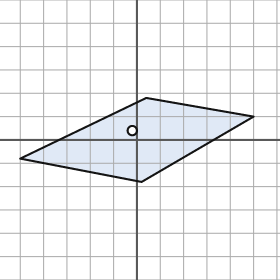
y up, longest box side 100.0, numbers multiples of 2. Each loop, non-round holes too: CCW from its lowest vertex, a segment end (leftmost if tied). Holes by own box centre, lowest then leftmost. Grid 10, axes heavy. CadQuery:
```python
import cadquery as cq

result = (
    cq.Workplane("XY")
    .moveTo(2.0, -18.0)
    .lineTo(50.0, 10.0)
    .lineTo(4.0, 18.0)
    .lineTo(-50.0, -8.0)
    .close()
    .moveTo(-2.0, 4.0)
    .circle(2.0)
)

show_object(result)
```